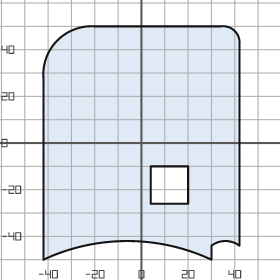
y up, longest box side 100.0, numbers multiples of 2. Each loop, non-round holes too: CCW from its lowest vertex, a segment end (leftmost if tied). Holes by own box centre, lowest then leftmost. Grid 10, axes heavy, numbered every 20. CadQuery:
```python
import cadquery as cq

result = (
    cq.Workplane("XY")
    .moveTo(-42.0, -50.0)
    .threePointArc((-6.0, -42.0), (30.0, -50.0))
    .lineTo(30.0, -44.0)
    .threePointArc((36.0, -42.0), (42.0, -44.0))
    .lineTo(42.0, 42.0)
    .threePointArc((40.0, 48.0), (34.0, 50.0))
    .lineTo(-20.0, 50.0)
    .threePointArc((-36.0, 44.0), (-42.0, 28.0))
    .close()
    .moveTo(4.0, -26.0)
    .lineTo(20.0, -26.0)
    .lineTo(20.0, -10.0)
    .lineTo(4.0, -10.0)
    .close()
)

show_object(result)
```